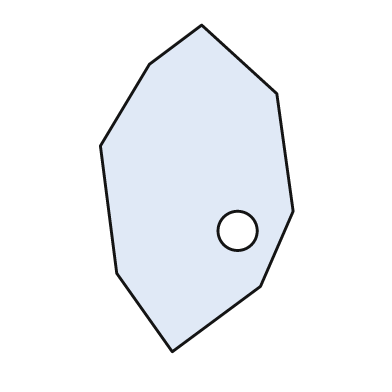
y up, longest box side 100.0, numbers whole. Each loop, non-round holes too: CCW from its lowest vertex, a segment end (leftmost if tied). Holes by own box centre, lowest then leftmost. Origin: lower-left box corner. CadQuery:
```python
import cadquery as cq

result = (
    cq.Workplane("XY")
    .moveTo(22.0, 0.0)
    .lineTo(49.0, 20.0)
    .lineTo(59.0, 43.0)
    .lineTo(54.0, 79.0)
    .lineTo(31.0, 100.0)
    .lineTo(15.0, 88.0)
    .lineTo(0.0, 63.0)
    .lineTo(5.0, 24.0)
    .close()
    .moveTo(42.0, 37.0)
    .circle(6.0)
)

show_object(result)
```